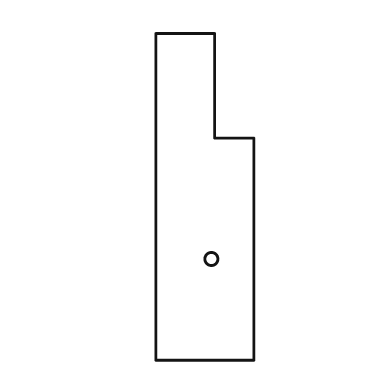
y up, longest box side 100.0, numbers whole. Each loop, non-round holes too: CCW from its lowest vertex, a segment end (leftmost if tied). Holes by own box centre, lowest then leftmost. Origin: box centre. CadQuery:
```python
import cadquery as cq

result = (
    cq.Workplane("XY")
    .moveTo(-15.0, -50.0)
    .lineTo(15.0, -50.0)
    .lineTo(15.0, 18.0)
    .lineTo(3.0, 18.0)
    .lineTo(3.0, 50.0)
    .lineTo(-15.0, 50.0)
    .close()
    .moveTo(2.0, -19.0)
    .circle(2.0)
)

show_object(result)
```